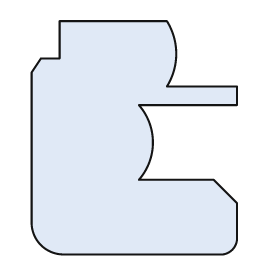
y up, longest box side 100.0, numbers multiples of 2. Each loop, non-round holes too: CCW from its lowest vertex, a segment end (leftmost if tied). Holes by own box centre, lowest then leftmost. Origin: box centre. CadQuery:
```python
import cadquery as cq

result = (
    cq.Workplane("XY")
    .moveTo(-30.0, -50.0)
    .lineTo(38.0, -50.0)
    .threePointArc((42.0, -48.0), (44.0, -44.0))
    .lineTo(44.0, -28.0)
    .lineTo(34.0, -18.0)
    .lineTo(2.0, -18.0)
    .threePointArc((8.0, -2.0), (2.0, 14.0))
    .lineTo(44.0, 14.0)
    .lineTo(44.0, 22.0)
    .lineTo(14.0, 22.0)
    .threePointArc((18.0, 36.0), (14.0, 50.0))
    .lineTo(-32.0, 50.0)
    .lineTo(-32.0, 34.0)
    .lineTo(-40.0, 34.0)
    .lineTo(-44.0, 28.0)
    .lineTo(-44.0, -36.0)
    .threePointArc((-40.0, -46.0), (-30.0, -50.0))
    .close()
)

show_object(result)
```